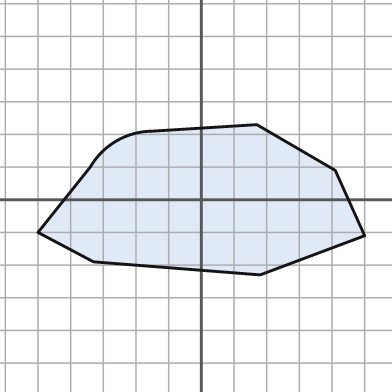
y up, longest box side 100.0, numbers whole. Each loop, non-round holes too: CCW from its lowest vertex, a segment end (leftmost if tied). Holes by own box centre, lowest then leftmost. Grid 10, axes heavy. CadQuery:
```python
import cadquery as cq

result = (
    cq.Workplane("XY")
    .moveTo(18.0, -23.0)
    .lineTo(50.0, -11.0)
    .lineTo(41.0, 9.0)
    .lineTo(17.0, 23.0)
    .lineTo(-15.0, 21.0)
    .threePointArc((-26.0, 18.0), (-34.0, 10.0))
    .lineTo(-50.0, -10.0)
    .lineTo(-33.0, -19.0)
    .close()
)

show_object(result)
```